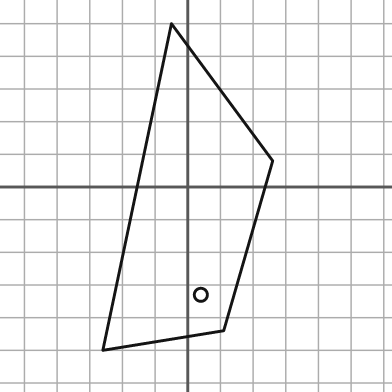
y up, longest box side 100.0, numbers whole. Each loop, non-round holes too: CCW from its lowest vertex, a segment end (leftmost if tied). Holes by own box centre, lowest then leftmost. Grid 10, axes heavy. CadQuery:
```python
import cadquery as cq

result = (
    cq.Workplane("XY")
    .moveTo(-26.0, -50.0)
    .lineTo(11.0, -44.0)
    .lineTo(26.0, 8.0)
    .lineTo(-5.0, 50.0)
    .close()
    .moveTo(4.0, -33.0)
    .circle(2.0)
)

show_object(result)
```